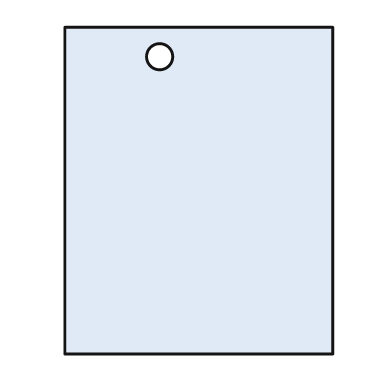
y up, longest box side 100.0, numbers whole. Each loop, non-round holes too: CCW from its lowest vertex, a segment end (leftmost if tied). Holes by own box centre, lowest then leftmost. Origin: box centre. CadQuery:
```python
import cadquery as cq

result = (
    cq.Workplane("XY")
    .moveTo(-41.0, -50.0)
    .lineTo(41.0, -50.0)
    .lineTo(41.0, 50.0)
    .lineTo(-41.0, 50.0)
    .close()
    .moveTo(-12.0, 41.0)
    .circle(4.0)
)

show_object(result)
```